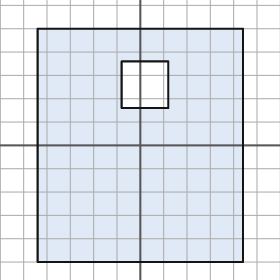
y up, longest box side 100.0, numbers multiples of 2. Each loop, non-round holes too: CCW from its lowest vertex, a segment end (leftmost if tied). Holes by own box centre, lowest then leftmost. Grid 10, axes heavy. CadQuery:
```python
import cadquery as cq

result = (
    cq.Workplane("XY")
    .moveTo(-44.0, -50.0)
    .lineTo(44.0, -50.0)
    .lineTo(44.0, 50.0)
    .lineTo(-44.0, 50.0)
    .close()
    .moveTo(-8.0, 16.0)
    .lineTo(12.0, 16.0)
    .lineTo(12.0, 36.0)
    .lineTo(-8.0, 36.0)
    .close()
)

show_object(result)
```